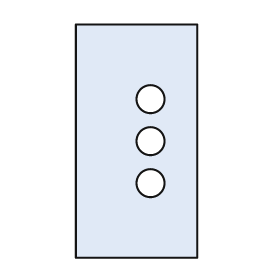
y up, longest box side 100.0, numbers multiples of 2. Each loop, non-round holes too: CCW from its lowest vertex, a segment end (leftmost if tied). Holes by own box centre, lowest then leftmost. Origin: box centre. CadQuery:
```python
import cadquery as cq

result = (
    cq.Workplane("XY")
    .moveTo(-26.0, -50.0)
    .lineTo(26.0, -50.0)
    .lineTo(26.0, 50.0)
    .lineTo(-26.0, 50.0)
    .close()
    .moveTo(6.0, -18.0)
    .circle(6.0)
    .moveTo(6.0, 0.0)
    .circle(6.0)
    .moveTo(6.0, 18.0)
    .circle(6.0)
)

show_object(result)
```